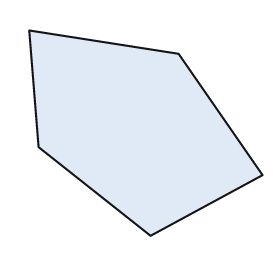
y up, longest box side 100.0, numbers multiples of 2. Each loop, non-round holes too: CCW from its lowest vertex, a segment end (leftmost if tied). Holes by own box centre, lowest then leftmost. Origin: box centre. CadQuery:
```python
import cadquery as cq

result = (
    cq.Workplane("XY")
    .moveTo(2.0, -44.0)
    .lineTo(50.0, -18.0)
    .lineTo(14.0, 34.0)
    .lineTo(-50.0, 44.0)
    .lineTo(-46.0, -6.0)
    .close()
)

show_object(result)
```